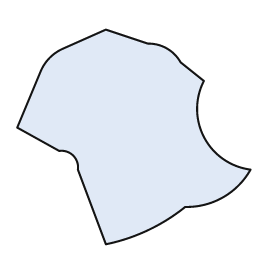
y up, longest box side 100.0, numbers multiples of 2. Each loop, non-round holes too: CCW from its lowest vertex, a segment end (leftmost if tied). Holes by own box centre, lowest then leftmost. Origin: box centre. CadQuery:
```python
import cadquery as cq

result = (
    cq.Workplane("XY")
    .moveTo(-12.0, -46.0)
    .threePointArc((6.0, -40.0), (22.0, -30.0))
    .threePointArc((38.0, -26.0), (50.0, -14.0))
    .threePointArc((30.0, 0.0), (30.0, 24.0))
    .lineTo(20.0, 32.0)
    .threePointArc((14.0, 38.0), (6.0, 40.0))
    .lineTo(-12.0, 46.0)
    .lineTo(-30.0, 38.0)
    .threePointArc((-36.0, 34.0), (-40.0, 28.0))
    .lineTo(-50.0, 4.0)
    .lineTo(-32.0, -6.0)
    .threePointArc((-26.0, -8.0), (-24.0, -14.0))
    .close()
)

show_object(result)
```